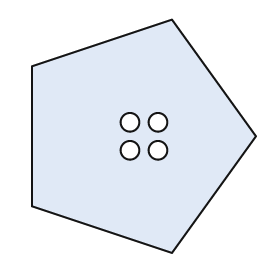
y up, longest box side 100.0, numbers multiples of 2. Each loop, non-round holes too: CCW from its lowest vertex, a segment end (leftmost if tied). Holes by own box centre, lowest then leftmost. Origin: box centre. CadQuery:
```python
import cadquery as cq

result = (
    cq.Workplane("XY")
    .moveTo(12.0, -50.0)
    .lineTo(48.0, 0.0)
    .lineTo(12.0, 50.0)
    .lineTo(-48.0, 30.0)
    .lineTo(-48.0, -30.0)
    .close()
    .moveTo(-6.0, -6.0)
    .circle(4.0)
    .moveTo(6.0, -6.0)
    .circle(4.0)
    .moveTo(-6.0, 6.0)
    .circle(4.0)
    .moveTo(6.0, 6.0)
    .circle(4.0)
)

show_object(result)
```